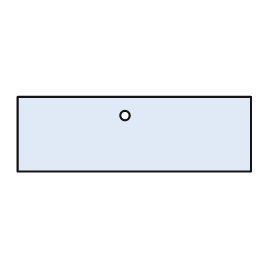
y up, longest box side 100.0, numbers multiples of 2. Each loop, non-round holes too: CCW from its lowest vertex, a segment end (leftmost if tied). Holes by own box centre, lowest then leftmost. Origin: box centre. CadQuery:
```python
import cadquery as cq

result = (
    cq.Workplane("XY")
    .moveTo(-50.0, -16.0)
    .lineTo(50.0, -16.0)
    .lineTo(50.0, 16.0)
    .lineTo(-50.0, 16.0)
    .close()
    .moveTo(-4.0, 8.0)
    .circle(2.0)
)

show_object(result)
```